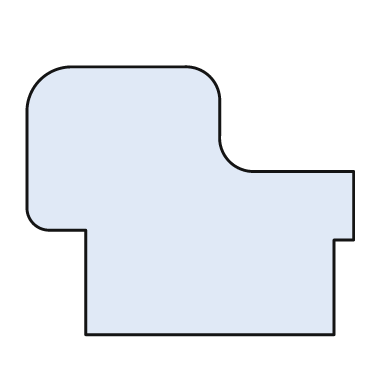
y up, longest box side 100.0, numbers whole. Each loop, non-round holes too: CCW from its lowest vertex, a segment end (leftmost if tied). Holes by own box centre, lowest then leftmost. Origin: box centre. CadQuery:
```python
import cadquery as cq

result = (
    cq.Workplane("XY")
    .moveTo(-32.0, -41.0)
    .lineTo(44.0, -41.0)
    .lineTo(44.0, -12.0)
    .lineTo(50.0, -12.0)
    .lineTo(50.0, 9.0)
    .lineTo(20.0, 9.0)
    .threePointArc((12.0, 12.0), (9.0, 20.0))
    .lineTo(9.0, 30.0)
    .threePointArc((6.0, 38.0), (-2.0, 41.0))
    .lineTo(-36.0, 41.0)
    .threePointArc((-46.0, 37.0), (-50.0, 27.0))
    .lineTo(-50.0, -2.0)
    .threePointArc((-48.0, -7.0), (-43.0, -9.0))
    .lineTo(-32.0, -9.0)
    .close()
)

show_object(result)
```